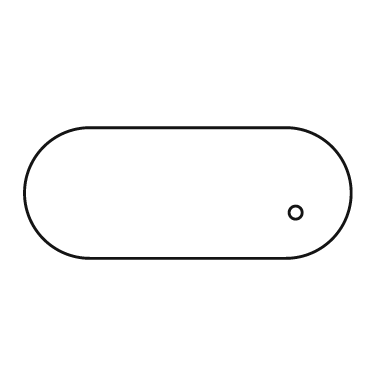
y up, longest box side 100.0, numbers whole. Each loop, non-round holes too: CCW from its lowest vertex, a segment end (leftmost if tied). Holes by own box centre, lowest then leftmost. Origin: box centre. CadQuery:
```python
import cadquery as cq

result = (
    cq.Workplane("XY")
    .moveTo(-30.0, -20.0)
    .lineTo(30.0, -20.0)
    .threePointArc((50.0, 0.0), (30.0, 20.0))
    .lineTo(-30.0, 20.0)
    .threePointArc((-50.0, 0.0), (-30.0, -20.0))
    .close()
    .moveTo(33.0, -6.0)
    .circle(2.0)
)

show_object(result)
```